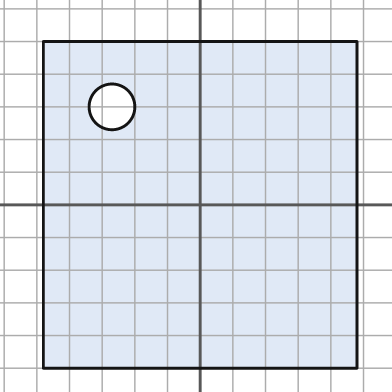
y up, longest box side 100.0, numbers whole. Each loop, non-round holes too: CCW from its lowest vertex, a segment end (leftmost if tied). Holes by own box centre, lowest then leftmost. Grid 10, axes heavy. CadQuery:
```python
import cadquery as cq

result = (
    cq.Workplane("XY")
    .moveTo(-48.0, -50.0)
    .lineTo(48.0, -50.0)
    .lineTo(48.0, 50.0)
    .lineTo(-48.0, 50.0)
    .close()
    .moveTo(-27.0, 30.0)
    .circle(7.0)
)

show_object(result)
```